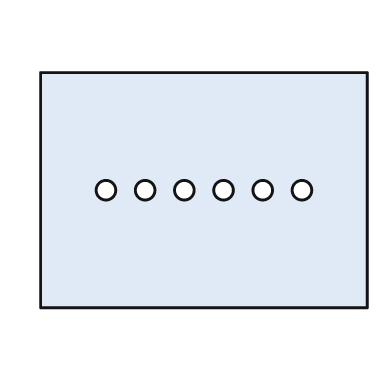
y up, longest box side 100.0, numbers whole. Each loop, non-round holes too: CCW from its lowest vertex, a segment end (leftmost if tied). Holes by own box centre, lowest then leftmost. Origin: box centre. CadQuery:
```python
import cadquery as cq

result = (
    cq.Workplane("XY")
    .moveTo(-50.0, -36.0)
    .lineTo(50.0, -36.0)
    .lineTo(50.0, 36.0)
    .lineTo(-50.0, 36.0)
    .close()
    .moveTo(-30.0, 0.0)
    .circle(3.0)
    .moveTo(-18.0, 0.0)
    .circle(3.0)
    .moveTo(-6.0, 0.0)
    .circle(3.0)
    .moveTo(6.0, 0.0)
    .circle(3.0)
    .moveTo(18.0, 0.0)
    .circle(3.0)
    .moveTo(30.0, 0.0)
    .circle(3.0)
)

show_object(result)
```